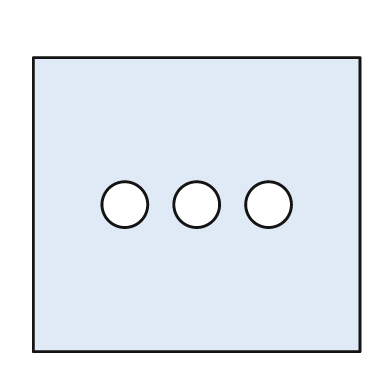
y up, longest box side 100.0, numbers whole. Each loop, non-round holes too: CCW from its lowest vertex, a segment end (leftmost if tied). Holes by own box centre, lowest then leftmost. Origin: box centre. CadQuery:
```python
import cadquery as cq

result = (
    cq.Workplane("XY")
    .moveTo(-50.0, -45.0)
    .lineTo(50.0, -45.0)
    .lineTo(50.0, 45.0)
    .lineTo(-50.0, 45.0)
    .close()
    .moveTo(-22.0, 0.0)
    .circle(7.0)
    .moveTo(0.0, 0.0)
    .circle(7.0)
    .moveTo(22.0, 0.0)
    .circle(7.0)
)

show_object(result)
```